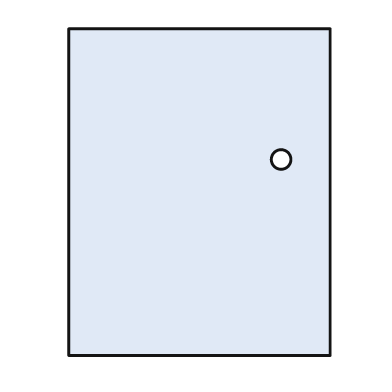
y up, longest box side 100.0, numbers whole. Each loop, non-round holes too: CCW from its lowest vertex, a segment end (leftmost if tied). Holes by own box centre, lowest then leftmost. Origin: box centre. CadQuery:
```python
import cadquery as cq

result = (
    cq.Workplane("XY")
    .moveTo(-40.0, -50.0)
    .lineTo(40.0, -50.0)
    .lineTo(40.0, 50.0)
    .lineTo(-40.0, 50.0)
    .close()
    .moveTo(25.0, 10.0)
    .circle(3.0)
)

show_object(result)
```